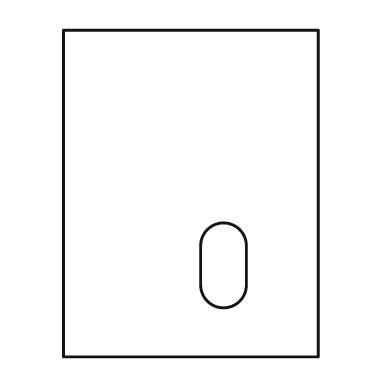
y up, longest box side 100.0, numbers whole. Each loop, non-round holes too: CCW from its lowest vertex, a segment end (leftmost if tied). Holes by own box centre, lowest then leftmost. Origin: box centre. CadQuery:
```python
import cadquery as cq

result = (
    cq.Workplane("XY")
    .moveTo(-39.0, -50.0)
    .lineTo(39.0, -50.0)
    .lineTo(39.0, 50.0)
    .lineTo(-39.0, 50.0)
    .close()
    .moveTo(3.0, -28.0)
    .threePointArc((10.0, -35.0), (17.0, -28.0))
    .lineTo(17.0, -16.0)
    .threePointArc((10.0, -9.0), (3.0, -16.0))
    .close()
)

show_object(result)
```